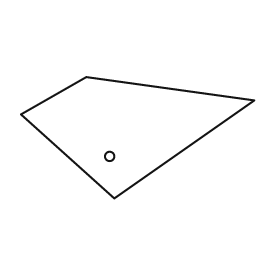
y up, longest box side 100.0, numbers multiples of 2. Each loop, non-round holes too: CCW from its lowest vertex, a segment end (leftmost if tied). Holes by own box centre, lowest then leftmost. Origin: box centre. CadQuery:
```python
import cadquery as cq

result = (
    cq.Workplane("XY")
    .moveTo(-10.0, -26.0)
    .lineTo(50.0, 16.0)
    .lineTo(-22.0, 26.0)
    .lineTo(-50.0, 10.0)
    .close()
    .moveTo(-12.0, -8.0)
    .circle(2.0)
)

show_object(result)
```